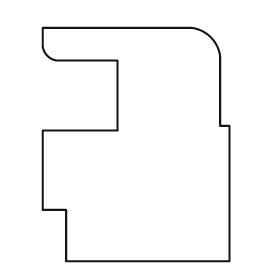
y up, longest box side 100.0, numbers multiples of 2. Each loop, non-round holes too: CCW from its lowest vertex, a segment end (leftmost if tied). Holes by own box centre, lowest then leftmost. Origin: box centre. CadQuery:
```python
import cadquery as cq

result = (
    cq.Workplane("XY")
    .moveTo(-30.0, -50.0)
    .lineTo(40.0, -50.0)
    .lineTo(40.0, 8.0)
    .lineTo(36.0, 8.0)
    .lineTo(36.0, 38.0)
    .threePointArc((32.0, 46.0), (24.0, 50.0))
    .lineTo(-40.0, 50.0)
    .lineTo(-40.0, 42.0)
    .threePointArc((-38.0, 38.0), (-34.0, 36.0))
    .lineTo(-8.0, 36.0)
    .lineTo(-8.0, 6.0)
    .lineTo(-40.0, 6.0)
    .lineTo(-40.0, -28.0)
    .lineTo(-30.0, -28.0)
    .close()
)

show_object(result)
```